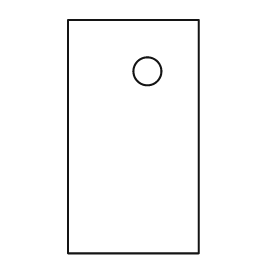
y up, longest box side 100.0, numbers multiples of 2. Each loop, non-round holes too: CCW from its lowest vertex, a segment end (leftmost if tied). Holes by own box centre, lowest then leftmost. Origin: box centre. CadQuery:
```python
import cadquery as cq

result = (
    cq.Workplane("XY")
    .moveTo(-28.0, -50.0)
    .lineTo(28.0, -50.0)
    .lineTo(28.0, 50.0)
    .lineTo(-28.0, 50.0)
    .close()
    .moveTo(6.0, 28.0)
    .circle(6.0)
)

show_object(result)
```